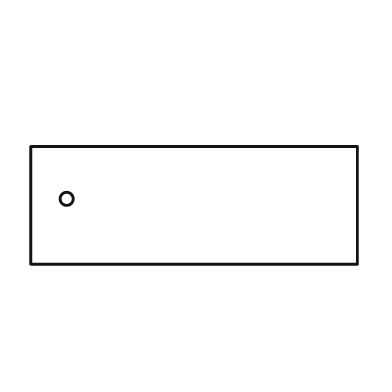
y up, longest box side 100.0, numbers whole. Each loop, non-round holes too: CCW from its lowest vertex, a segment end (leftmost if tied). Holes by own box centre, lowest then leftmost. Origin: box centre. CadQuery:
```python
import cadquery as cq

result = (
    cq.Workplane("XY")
    .moveTo(-50.0, -18.0)
    .lineTo(50.0, -18.0)
    .lineTo(50.0, 18.0)
    .lineTo(-50.0, 18.0)
    .close()
    .moveTo(-39.0, 2.0)
    .circle(2.0)
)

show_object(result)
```